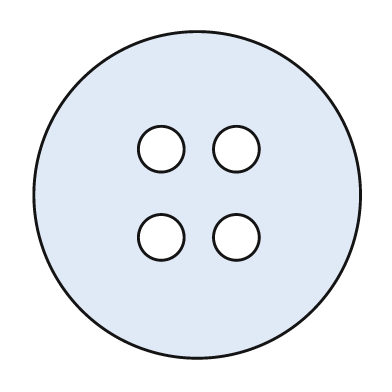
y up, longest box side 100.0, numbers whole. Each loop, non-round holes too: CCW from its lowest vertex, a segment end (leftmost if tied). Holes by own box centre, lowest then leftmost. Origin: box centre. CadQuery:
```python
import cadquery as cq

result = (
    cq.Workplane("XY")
    .moveTo(0.0, 0.0)
    .circle(50.0)
    .moveTo(-11.0, -13.0)
    .circle(7.0)
    .moveTo(12.0, -13.0)
    .circle(7.0)
    .moveTo(-11.0, 14.0)
    .circle(7.0)
    .moveTo(12.0, 14.0)
    .circle(7.0)
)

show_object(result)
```